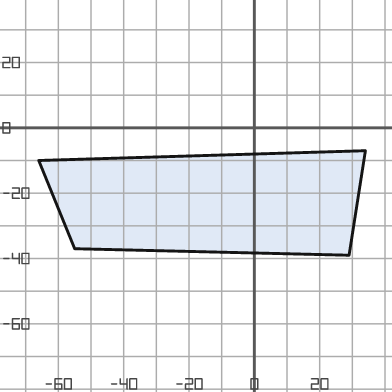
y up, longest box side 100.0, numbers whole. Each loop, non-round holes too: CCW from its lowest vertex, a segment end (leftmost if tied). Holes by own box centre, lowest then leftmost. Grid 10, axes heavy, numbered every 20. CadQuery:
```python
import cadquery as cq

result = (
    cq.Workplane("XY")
    .moveTo(29.0, -39.0)
    .lineTo(34.0, -7.0)
    .lineTo(-66.0, -10.0)
    .lineTo(-55.0, -37.0)
    .close()
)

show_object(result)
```